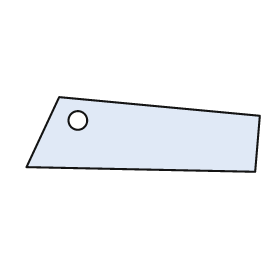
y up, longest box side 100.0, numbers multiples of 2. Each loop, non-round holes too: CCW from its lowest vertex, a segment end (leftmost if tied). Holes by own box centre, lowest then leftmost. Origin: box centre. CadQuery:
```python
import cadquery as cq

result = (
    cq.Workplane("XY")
    .moveTo(48.0, -16.0)
    .lineTo(50.0, 8.0)
    .lineTo(-36.0, 16.0)
    .lineTo(-50.0, -14.0)
    .close()
    .moveTo(-28.0, 6.0)
    .circle(4.0)
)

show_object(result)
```